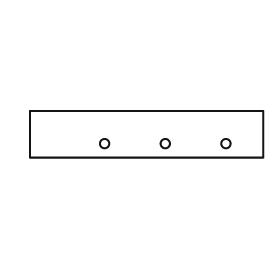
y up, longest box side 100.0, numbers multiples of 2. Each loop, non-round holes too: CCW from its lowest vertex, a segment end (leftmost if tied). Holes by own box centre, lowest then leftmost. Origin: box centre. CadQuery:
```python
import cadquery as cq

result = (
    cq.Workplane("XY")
    .moveTo(-50.0, -10.0)
    .lineTo(50.0, -10.0)
    .lineTo(50.0, 10.0)
    .lineTo(-50.0, 10.0)
    .close()
    .moveTo(-18.0, -4.0)
    .circle(2.0)
    .moveTo(8.0, -4.0)
    .circle(2.0)
    .moveTo(34.0, -4.0)
    .circle(2.0)
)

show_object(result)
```